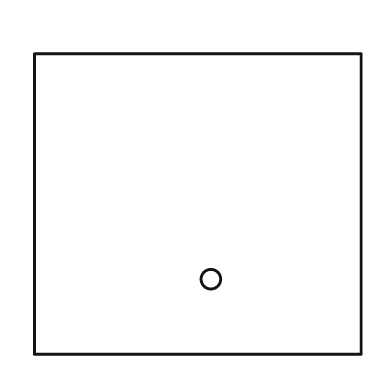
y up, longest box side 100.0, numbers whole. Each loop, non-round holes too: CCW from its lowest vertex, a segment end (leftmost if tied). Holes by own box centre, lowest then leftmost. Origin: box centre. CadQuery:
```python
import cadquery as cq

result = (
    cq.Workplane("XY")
    .moveTo(-50.0, -46.0)
    .lineTo(50.0, -46.0)
    .lineTo(50.0, 46.0)
    .lineTo(-50.0, 46.0)
    .close()
    .moveTo(4.0, -23.0)
    .circle(3.0)
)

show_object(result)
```